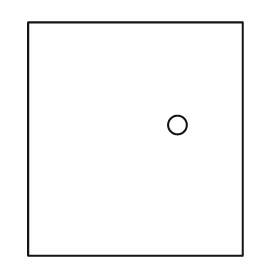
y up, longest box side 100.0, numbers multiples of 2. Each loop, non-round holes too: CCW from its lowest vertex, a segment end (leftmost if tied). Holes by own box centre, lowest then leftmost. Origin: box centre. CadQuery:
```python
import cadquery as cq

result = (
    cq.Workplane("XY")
    .moveTo(-46.0, -50.0)
    .lineTo(46.0, -50.0)
    .lineTo(46.0, 50.0)
    .lineTo(-46.0, 50.0)
    .close()
    .moveTo(18.0, 6.0)
    .circle(4.0)
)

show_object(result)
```